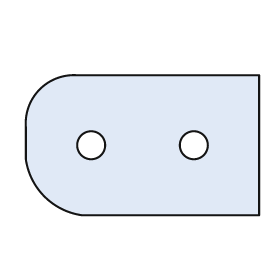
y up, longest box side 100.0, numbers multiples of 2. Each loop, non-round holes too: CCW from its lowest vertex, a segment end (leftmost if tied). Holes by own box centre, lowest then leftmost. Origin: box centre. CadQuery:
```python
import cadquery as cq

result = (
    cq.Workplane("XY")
    .moveTo(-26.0, -30.0)
    .lineTo(50.0, -30.0)
    .lineTo(50.0, 30.0)
    .lineTo(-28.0, 30.0)
    .threePointArc((-44.0, 24.0), (-50.0, 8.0))
    .lineTo(-50.0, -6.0)
    .threePointArc((-42.0, -22.0), (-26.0, -30.0))
    .close()
    .moveTo(-22.0, 0.0)
    .circle(6.0)
    .moveTo(22.0, 0.0)
    .circle(6.0)
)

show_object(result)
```